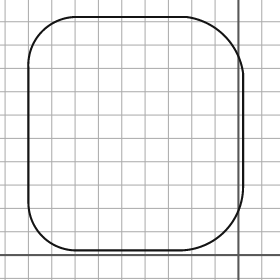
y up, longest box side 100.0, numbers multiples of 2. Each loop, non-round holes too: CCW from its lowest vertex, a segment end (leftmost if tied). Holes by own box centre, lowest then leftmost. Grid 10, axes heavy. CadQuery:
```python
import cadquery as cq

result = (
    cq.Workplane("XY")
    .moveTo(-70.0, 2.0)
    .lineTo(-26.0, 2.0)
    .threePointArc((-6.0, 10.0), (2.0, 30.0))
    .lineTo(2.0, 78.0)
    .threePointArc((-6.0, 94.0), (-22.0, 102.0))
    .lineTo(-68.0, 102.0)
    .threePointArc((-84.0, 96.0), (-90.0, 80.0))
    .lineTo(-90.0, 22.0)
    .threePointArc((-84.0, 8.0), (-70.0, 2.0))
    .close()
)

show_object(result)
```